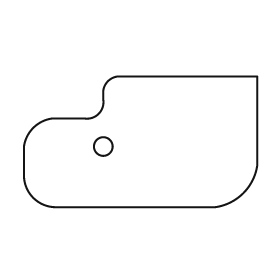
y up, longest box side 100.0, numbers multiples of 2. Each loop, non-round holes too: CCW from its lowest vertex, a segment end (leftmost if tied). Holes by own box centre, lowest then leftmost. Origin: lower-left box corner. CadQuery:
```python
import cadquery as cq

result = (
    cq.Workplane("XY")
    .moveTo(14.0, 0.0)
    .lineTo(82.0, 0.0)
    .threePointArc((94.0, 6.0), (100.0, 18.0))
    .lineTo(100.0, 56.0)
    .lineTo(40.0, 56.0)
    .threePointArc((36.0, 54.0), (34.0, 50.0))
    .lineTo(34.0, 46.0)
    .threePointArc((32.0, 40.0), (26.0, 38.0))
    .lineTo(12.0, 38.0)
    .threePointArc((4.0, 34.0), (0.0, 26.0))
    .lineTo(0.0, 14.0)
    .threePointArc((4.0, 4.0), (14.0, 0.0))
    .close()
    .moveTo(34.0, 26.0)
    .circle(4.0)
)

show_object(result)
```